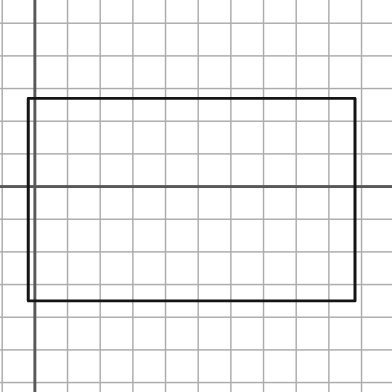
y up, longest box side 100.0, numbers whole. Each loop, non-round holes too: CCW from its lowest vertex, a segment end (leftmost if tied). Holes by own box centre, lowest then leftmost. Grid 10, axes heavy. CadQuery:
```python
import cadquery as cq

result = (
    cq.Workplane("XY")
    .moveTo(-2.0, -35.0)
    .lineTo(98.0, -35.0)
    .lineTo(98.0, 27.0)
    .lineTo(-2.0, 27.0)
    .close()
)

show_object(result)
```